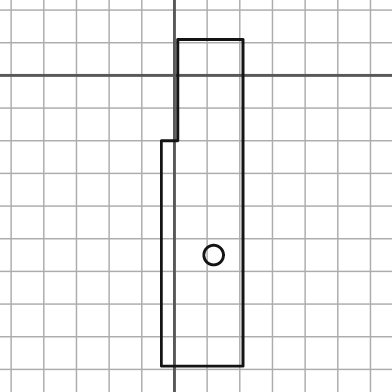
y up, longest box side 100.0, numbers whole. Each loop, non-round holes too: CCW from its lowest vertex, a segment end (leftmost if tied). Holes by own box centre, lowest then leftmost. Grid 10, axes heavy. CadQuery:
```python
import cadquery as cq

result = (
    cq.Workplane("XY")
    .moveTo(-4.0, -89.0)
    .lineTo(21.0, -89.0)
    .lineTo(21.0, 11.0)
    .lineTo(1.0, 11.0)
    .lineTo(1.0, -20.0)
    .lineTo(-4.0, -20.0)
    .close()
    .moveTo(12.0, -55.0)
    .circle(3.0)
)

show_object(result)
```